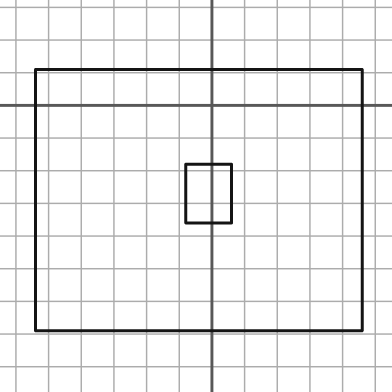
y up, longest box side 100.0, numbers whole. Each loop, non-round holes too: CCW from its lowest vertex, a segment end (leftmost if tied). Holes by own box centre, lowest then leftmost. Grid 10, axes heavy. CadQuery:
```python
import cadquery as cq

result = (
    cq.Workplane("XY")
    .moveTo(-54.0, -69.0)
    .lineTo(46.0, -69.0)
    .lineTo(46.0, 11.0)
    .lineTo(-54.0, 11.0)
    .close()
    .moveTo(-8.0, -36.0)
    .lineTo(6.0, -36.0)
    .lineTo(6.0, -18.0)
    .lineTo(-8.0, -18.0)
    .close()
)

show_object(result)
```